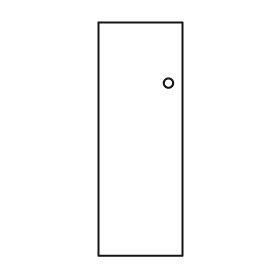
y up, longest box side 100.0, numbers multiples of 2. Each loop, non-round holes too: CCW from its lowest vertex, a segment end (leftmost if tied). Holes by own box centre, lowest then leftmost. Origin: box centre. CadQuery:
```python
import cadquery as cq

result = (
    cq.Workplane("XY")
    .moveTo(-18.0, -50.0)
    .lineTo(18.0, -50.0)
    .lineTo(18.0, 50.0)
    .lineTo(-18.0, 50.0)
    .close()
    .moveTo(12.0, 24.0)
    .circle(2.0)
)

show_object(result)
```